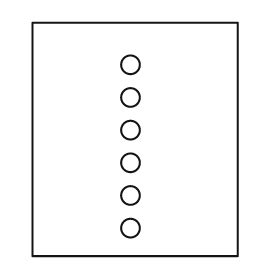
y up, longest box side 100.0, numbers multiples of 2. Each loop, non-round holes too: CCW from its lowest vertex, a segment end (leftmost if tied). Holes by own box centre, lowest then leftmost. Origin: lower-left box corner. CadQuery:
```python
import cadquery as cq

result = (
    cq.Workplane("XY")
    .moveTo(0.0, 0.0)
    .lineTo(88.0, 0.0)
    .lineTo(88.0, 100.0)
    .lineTo(0.0, 100.0)
    .close()
    .moveTo(42.0, 12.0)
    .circle(4.0)
    .moveTo(42.0, 26.0)
    .circle(4.0)
    .moveTo(42.0, 40.0)
    .circle(4.0)
    .moveTo(42.0, 54.0)
    .circle(4.0)
    .moveTo(42.0, 68.0)
    .circle(4.0)
    .moveTo(42.0, 82.0)
    .circle(4.0)
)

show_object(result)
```